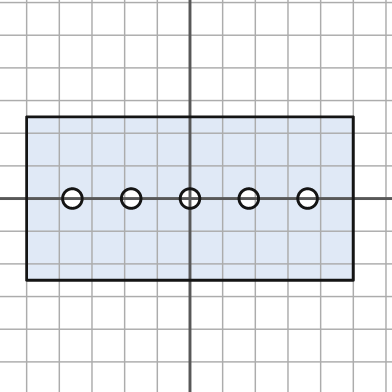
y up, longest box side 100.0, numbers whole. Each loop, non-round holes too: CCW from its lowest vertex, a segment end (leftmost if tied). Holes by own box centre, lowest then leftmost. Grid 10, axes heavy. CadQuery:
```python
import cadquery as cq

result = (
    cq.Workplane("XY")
    .moveTo(-50.0, -25.0)
    .lineTo(50.0, -25.0)
    .lineTo(50.0, 25.0)
    .lineTo(-50.0, 25.0)
    .close()
    .moveTo(-36.0, 0.0)
    .circle(3.0)
    .moveTo(-18.0, 0.0)
    .circle(3.0)
    .moveTo(0.0, 0.0)
    .circle(3.0)
    .moveTo(18.0, 0.0)
    .circle(3.0)
    .moveTo(36.0, 0.0)
    .circle(3.0)
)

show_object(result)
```